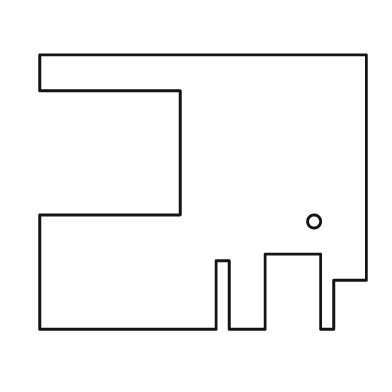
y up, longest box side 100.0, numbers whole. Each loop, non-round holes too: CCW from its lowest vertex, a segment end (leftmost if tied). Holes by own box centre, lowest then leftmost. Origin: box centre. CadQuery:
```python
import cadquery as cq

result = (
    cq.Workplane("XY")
    .moveTo(-50.0, -42.0)
    .lineTo(4.0, -42.0)
    .lineTo(4.0, -21.0)
    .lineTo(8.0, -21.0)
    .lineTo(8.0, -42.0)
    .lineTo(19.0, -42.0)
    .lineTo(19.0, -19.0)
    .lineTo(36.0, -19.0)
    .lineTo(36.0, -42.0)
    .lineTo(40.0, -42.0)
    .lineTo(40.0, -27.0)
    .lineTo(50.0, -27.0)
    .lineTo(50.0, 42.0)
    .lineTo(-50.0, 42.0)
    .lineTo(-50.0, 31.0)
    .lineTo(-7.0, 31.0)
    .lineTo(-7.0, -7.0)
    .lineTo(-50.0, -7.0)
    .close()
    .moveTo(34.0, -9.0)
    .circle(2.0)
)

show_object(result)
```